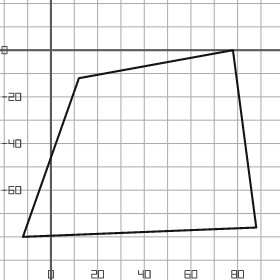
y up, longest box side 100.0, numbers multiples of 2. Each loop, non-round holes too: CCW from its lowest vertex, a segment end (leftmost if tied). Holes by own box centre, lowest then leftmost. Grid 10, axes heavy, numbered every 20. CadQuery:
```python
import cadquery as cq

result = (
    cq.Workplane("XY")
    .moveTo(-12.0, -80.0)
    .lineTo(88.0, -76.0)
    .lineTo(78.0, 0.0)
    .lineTo(12.0, -12.0)
    .close()
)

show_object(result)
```